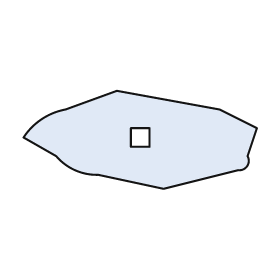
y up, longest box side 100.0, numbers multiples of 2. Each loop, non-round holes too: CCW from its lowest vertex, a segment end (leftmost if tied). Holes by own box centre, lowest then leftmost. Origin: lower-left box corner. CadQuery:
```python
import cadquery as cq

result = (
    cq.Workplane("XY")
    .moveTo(60.0, 0.0)
    .lineTo(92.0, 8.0)
    .threePointArc((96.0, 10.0), (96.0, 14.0))
    .lineTo(100.0, 26.0)
    .lineTo(84.0, 34.0)
    .lineTo(40.0, 42.0)
    .lineTo(18.0, 34.0)
    .threePointArc((8.0, 30.0), (0.0, 22.0))
    .lineTo(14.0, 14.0)
    .threePointArc((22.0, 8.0), (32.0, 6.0))
    .close()
    .moveTo(46.0, 18.0)
    .lineTo(54.0, 18.0)
    .lineTo(54.0, 26.0)
    .lineTo(46.0, 26.0)
    .close()
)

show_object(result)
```